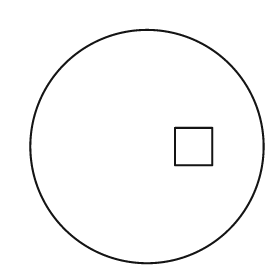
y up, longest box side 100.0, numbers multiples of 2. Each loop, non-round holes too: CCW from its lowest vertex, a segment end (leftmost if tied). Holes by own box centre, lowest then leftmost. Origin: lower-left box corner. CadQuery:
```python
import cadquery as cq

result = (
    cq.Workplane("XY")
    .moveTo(50.0, 50.0)
    .circle(50.0)
    .moveTo(62.0, 42.0)
    .lineTo(78.0, 42.0)
    .lineTo(78.0, 58.0)
    .lineTo(62.0, 58.0)
    .close()
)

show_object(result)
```